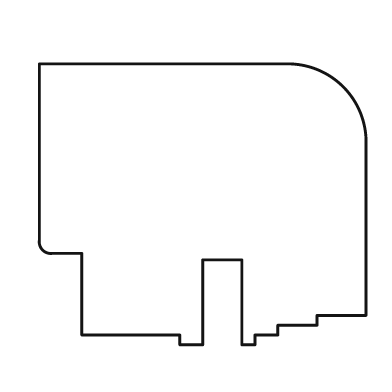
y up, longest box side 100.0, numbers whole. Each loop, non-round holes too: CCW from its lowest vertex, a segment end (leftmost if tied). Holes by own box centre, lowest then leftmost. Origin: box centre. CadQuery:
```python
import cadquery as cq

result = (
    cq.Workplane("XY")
    .moveTo(-7.0, -43.0)
    .lineTo(0.0, -43.0)
    .lineTo(0.0, -17.0)
    .lineTo(12.0, -17.0)
    .lineTo(12.0, -43.0)
    .lineTo(16.0, -43.0)
    .lineTo(16.0, -40.0)
    .lineTo(23.0, -40.0)
    .lineTo(23.0, -37.0)
    .lineTo(35.0, -37.0)
    .lineTo(35.0, -34.0)
    .lineTo(50.0, -34.0)
    .lineTo(50.0, 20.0)
    .threePointArc((43.0, 36.0), (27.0, 43.0))
    .lineTo(-50.0, 43.0)
    .lineTo(-50.0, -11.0)
    .threePointArc((-49.0, -14.0), (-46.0, -15.0))
    .lineTo(-37.0, -15.0)
    .lineTo(-37.0, -40.0)
    .lineTo(-7.0, -40.0)
    .close()
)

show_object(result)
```